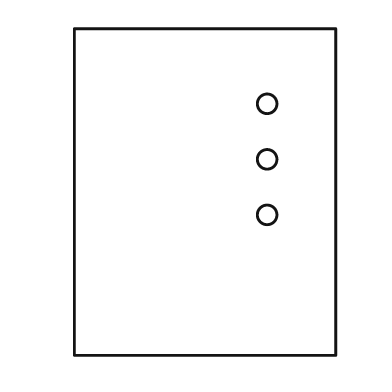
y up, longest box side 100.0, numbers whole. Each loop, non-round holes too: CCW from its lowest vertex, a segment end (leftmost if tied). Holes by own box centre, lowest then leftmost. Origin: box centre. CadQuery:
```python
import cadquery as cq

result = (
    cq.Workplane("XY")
    .moveTo(-40.0, -50.0)
    .lineTo(40.0, -50.0)
    .lineTo(40.0, 50.0)
    .lineTo(-40.0, 50.0)
    .close()
    .moveTo(19.0, -7.0)
    .circle(3.0)
    .moveTo(19.0, 10.0)
    .circle(3.0)
    .moveTo(19.0, 27.0)
    .circle(3.0)
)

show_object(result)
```